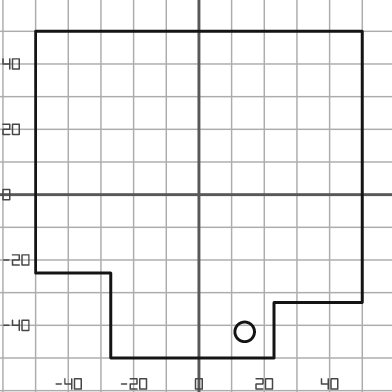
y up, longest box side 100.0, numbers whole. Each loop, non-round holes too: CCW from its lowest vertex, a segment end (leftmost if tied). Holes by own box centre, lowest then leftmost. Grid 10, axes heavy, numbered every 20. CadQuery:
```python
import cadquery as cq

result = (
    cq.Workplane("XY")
    .moveTo(-27.0, -50.0)
    .lineTo(23.0, -50.0)
    .lineTo(23.0, -33.0)
    .lineTo(50.0, -33.0)
    .lineTo(50.0, 50.0)
    .lineTo(-50.0, 50.0)
    .lineTo(-50.0, -24.0)
    .lineTo(-27.0, -24.0)
    .close()
    .moveTo(14.0, -42.0)
    .circle(3.0)
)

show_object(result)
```